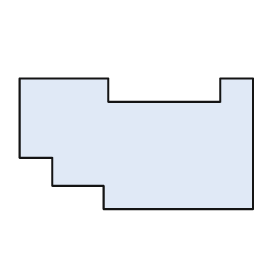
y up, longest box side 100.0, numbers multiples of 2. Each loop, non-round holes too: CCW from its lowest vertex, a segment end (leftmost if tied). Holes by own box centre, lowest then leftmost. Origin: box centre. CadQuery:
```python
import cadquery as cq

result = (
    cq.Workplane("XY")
    .moveTo(-14.0, -28.0)
    .lineTo(50.0, -28.0)
    .lineTo(50.0, 28.0)
    .lineTo(36.0, 28.0)
    .lineTo(36.0, 18.0)
    .lineTo(-12.0, 18.0)
    .lineTo(-12.0, 28.0)
    .lineTo(-50.0, 28.0)
    .lineTo(-50.0, -6.0)
    .lineTo(-36.0, -6.0)
    .lineTo(-36.0, -18.0)
    .lineTo(-14.0, -18.0)
    .close()
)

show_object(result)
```